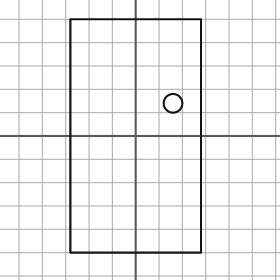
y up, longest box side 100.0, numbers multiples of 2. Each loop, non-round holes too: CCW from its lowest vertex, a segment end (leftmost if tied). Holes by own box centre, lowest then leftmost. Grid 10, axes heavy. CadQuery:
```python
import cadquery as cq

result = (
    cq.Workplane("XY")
    .moveTo(-28.0, -50.0)
    .lineTo(28.0, -50.0)
    .lineTo(28.0, 50.0)
    .lineTo(-28.0, 50.0)
    .close()
    .moveTo(16.0, 14.0)
    .circle(4.0)
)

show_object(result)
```